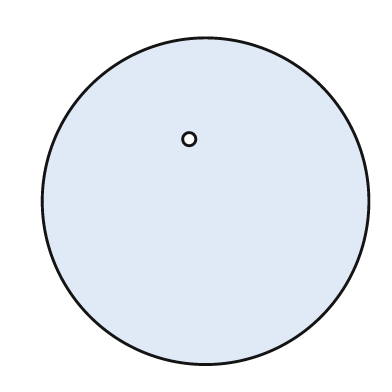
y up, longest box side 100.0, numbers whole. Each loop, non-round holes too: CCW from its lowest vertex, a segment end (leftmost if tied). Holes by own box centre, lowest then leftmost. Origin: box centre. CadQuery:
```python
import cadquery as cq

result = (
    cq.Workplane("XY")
    .moveTo(0.0, 0.0)
    .circle(50.0)
    .moveTo(-5.0, 19.0)
    .circle(2.0)
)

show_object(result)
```